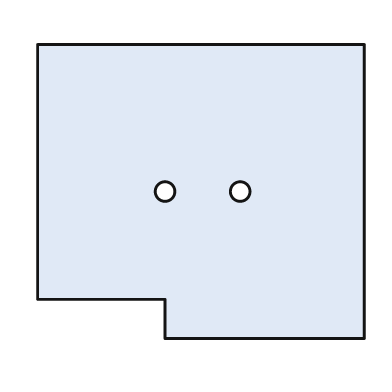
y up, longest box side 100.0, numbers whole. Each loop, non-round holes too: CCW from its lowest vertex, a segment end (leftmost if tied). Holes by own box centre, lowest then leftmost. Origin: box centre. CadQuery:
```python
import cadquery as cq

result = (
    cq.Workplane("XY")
    .moveTo(-11.0, -45.0)
    .lineTo(50.0, -45.0)
    .lineTo(50.0, 45.0)
    .lineTo(-50.0, 45.0)
    .lineTo(-50.0, -33.0)
    .lineTo(-11.0, -33.0)
    .close()
    .moveTo(-11.0, 0.0)
    .circle(3.0)
    .moveTo(12.0, 0.0)
    .circle(3.0)
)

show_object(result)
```